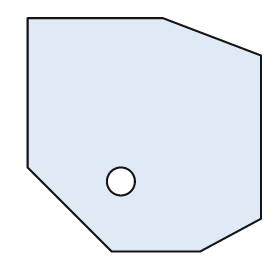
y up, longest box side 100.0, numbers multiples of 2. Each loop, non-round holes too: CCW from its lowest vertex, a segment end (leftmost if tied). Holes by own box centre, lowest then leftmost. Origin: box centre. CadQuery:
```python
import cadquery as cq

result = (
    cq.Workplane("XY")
    .moveTo(-14.0, -50.0)
    .lineTo(24.0, -50.0)
    .lineTo(50.0, -36.0)
    .lineTo(50.0, 34.0)
    .lineTo(8.0, 50.0)
    .lineTo(-50.0, 50.0)
    .lineTo(-50.0, -14.0)
    .close()
    .moveTo(-10.0, -20.0)
    .circle(6.0)
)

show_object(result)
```